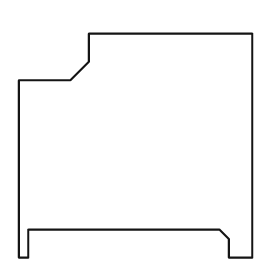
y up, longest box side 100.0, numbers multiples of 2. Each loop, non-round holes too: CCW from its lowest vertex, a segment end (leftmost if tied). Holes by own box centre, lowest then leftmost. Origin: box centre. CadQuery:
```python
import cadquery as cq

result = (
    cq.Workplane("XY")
    .moveTo(-50.0, -48.0)
    .lineTo(-46.0, -48.0)
    .lineTo(-46.0, -36.0)
    .lineTo(36.0, -36.0)
    .lineTo(40.0, -40.0)
    .lineTo(40.0, -48.0)
    .lineTo(50.0, -48.0)
    .lineTo(50.0, 48.0)
    .lineTo(-20.0, 48.0)
    .lineTo(-20.0, 36.0)
    .lineTo(-28.0, 28.0)
    .lineTo(-50.0, 28.0)
    .close()
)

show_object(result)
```